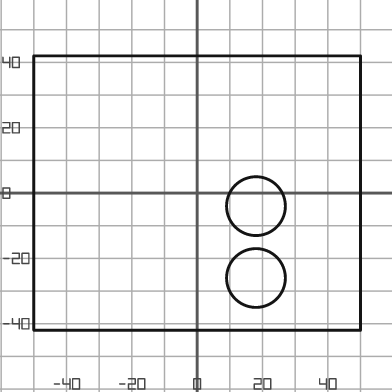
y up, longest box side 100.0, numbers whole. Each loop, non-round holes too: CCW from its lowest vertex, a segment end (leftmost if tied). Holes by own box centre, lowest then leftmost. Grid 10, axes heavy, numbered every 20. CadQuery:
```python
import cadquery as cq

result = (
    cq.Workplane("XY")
    .moveTo(-50.0, -42.0)
    .lineTo(50.0, -42.0)
    .lineTo(50.0, 42.0)
    .lineTo(-50.0, 42.0)
    .close()
    .moveTo(18.0, -26.0)
    .circle(9.0)
    .moveTo(18.0, -4.0)
    .circle(9.0)
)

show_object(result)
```